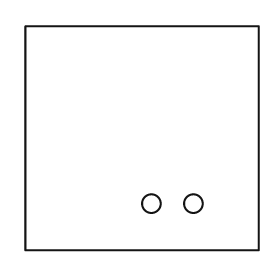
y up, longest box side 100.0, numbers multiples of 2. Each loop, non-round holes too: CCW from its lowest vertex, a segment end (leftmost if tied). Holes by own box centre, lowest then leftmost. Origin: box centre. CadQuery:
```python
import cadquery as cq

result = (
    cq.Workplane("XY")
    .moveTo(-50.0, -48.0)
    .lineTo(50.0, -48.0)
    .lineTo(50.0, 48.0)
    .lineTo(-50.0, 48.0)
    .close()
    .moveTo(4.0, -28.0)
    .circle(4.0)
    .moveTo(22.0, -28.0)
    .circle(4.0)
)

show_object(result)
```